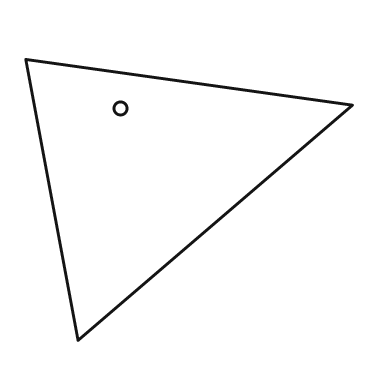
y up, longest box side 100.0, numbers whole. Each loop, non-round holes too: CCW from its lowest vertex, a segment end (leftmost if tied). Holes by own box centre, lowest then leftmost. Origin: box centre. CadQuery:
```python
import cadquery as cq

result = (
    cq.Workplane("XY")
    .moveTo(-34.0, -43.0)
    .lineTo(50.0, 29.0)
    .lineTo(-50.0, 43.0)
    .close()
    .moveTo(-21.0, 28.0)
    .circle(2.0)
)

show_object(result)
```